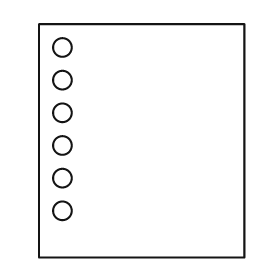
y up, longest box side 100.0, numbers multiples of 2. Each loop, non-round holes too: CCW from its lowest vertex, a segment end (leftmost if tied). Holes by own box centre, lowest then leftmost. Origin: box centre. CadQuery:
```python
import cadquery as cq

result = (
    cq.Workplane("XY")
    .moveTo(-44.0, -50.0)
    .lineTo(44.0, -50.0)
    .lineTo(44.0, 50.0)
    .lineTo(-44.0, 50.0)
    .close()
    .moveTo(-34.0, -30.0)
    .circle(4.0)
    .moveTo(-34.0, -16.0)
    .circle(4.0)
    .moveTo(-34.0, -2.0)
    .circle(4.0)
    .moveTo(-34.0, 12.0)
    .circle(4.0)
    .moveTo(-34.0, 26.0)
    .circle(4.0)
    .moveTo(-34.0, 40.0)
    .circle(4.0)
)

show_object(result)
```